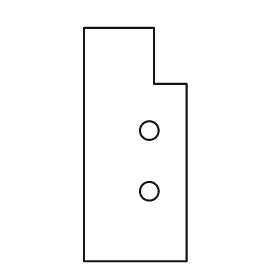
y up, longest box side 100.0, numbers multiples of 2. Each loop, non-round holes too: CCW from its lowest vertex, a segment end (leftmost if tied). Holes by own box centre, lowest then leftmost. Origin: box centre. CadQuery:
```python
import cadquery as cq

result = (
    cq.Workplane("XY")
    .moveTo(-22.0, -50.0)
    .lineTo(22.0, -50.0)
    .lineTo(22.0, 26.0)
    .lineTo(8.0, 26.0)
    .lineTo(8.0, 50.0)
    .lineTo(-22.0, 50.0)
    .close()
    .moveTo(6.0, -20.0)
    .circle(4.0)
    .moveTo(6.0, 6.0)
    .circle(4.0)
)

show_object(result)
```